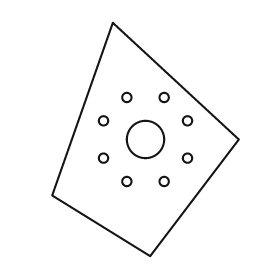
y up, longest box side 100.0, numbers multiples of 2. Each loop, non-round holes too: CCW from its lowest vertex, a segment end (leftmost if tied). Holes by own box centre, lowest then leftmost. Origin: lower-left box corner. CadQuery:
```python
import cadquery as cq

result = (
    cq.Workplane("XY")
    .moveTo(42.0, 0.0)
    .lineTo(80.0, 50.0)
    .lineTo(26.0, 100.0)
    .lineTo(0.0, 26.0)
    .close()
    .moveTo(32.0, 32.0)
    .circle(2.0)
    .moveTo(48.0, 32.0)
    .circle(2.0)
    .moveTo(22.0, 42.0)
    .circle(2.0)
    .moveTo(58.0, 42.0)
    .circle(2.0)
    .moveTo(40.0, 50.0)
    .circle(8.0)
    .moveTo(22.0, 58.0)
    .circle(2.0)
    .moveTo(58.0, 58.0)
    .circle(2.0)
    .moveTo(32.0, 68.0)
    .circle(2.0)
    .moveTo(48.0, 68.0)
    .circle(2.0)
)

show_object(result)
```